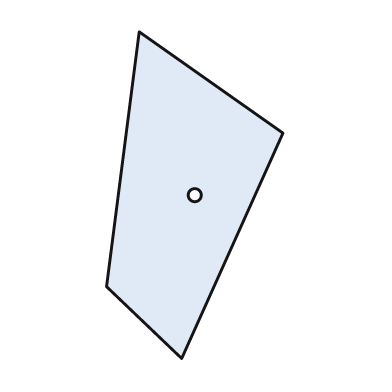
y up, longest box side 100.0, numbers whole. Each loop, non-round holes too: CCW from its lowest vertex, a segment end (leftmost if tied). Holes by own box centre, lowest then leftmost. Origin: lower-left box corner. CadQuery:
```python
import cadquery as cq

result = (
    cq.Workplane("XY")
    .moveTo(23.0, 0.0)
    .lineTo(54.0, 69.0)
    .lineTo(10.0, 100.0)
    .lineTo(0.0, 22.0)
    .close()
    .moveTo(27.0, 50.0)
    .circle(2.0)
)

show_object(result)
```